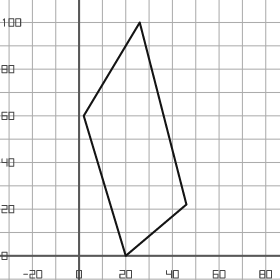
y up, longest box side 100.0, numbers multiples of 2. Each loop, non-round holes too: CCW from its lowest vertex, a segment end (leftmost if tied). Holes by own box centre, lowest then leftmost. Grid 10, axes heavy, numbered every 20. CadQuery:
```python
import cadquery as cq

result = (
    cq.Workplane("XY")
    .moveTo(20.0, 0.0)
    .lineTo(46.0, 22.0)
    .lineTo(26.0, 100.0)
    .lineTo(2.0, 60.0)
    .close()
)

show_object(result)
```